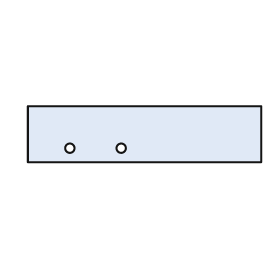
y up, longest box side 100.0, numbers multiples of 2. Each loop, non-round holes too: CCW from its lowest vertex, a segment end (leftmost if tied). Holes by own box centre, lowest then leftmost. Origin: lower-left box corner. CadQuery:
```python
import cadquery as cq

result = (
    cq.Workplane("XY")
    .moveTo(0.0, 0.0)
    .lineTo(100.0, 0.0)
    .lineTo(100.0, 24.0)
    .lineTo(0.0, 24.0)
    .close()
    .moveTo(18.0, 6.0)
    .circle(2.0)
    .moveTo(40.0, 6.0)
    .circle(2.0)
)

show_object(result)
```